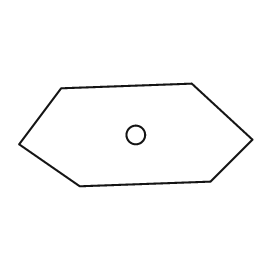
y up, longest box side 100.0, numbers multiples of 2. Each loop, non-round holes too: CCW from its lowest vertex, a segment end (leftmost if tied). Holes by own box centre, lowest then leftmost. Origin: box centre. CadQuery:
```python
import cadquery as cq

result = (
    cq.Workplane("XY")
    .moveTo(-24.0, -22.0)
    .lineTo(32.0, -20.0)
    .lineTo(50.0, -2.0)
    .lineTo(24.0, 22.0)
    .lineTo(-32.0, 20.0)
    .lineTo(-50.0, -4.0)
    .close()
    .moveTo(0.0, 0.0)
    .circle(4.0)
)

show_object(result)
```